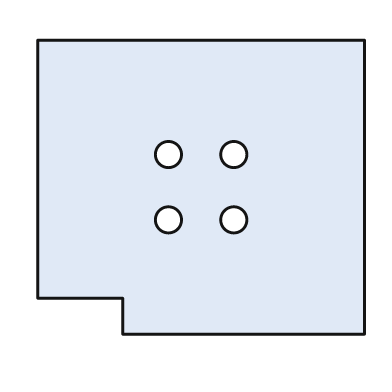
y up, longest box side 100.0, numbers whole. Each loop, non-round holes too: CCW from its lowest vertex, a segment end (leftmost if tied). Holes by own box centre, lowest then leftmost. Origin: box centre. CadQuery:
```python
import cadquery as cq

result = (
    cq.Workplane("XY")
    .moveTo(-24.0, -45.0)
    .lineTo(50.0, -45.0)
    .lineTo(50.0, 45.0)
    .lineTo(-50.0, 45.0)
    .lineTo(-50.0, -34.0)
    .lineTo(-24.0, -34.0)
    .close()
    .moveTo(-10.0, -10.0)
    .circle(4.0)
    .moveTo(10.0, -10.0)
    .circle(4.0)
    .moveTo(-10.0, 10.0)
    .circle(4.0)
    .moveTo(10.0, 10.0)
    .circle(4.0)
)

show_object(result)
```